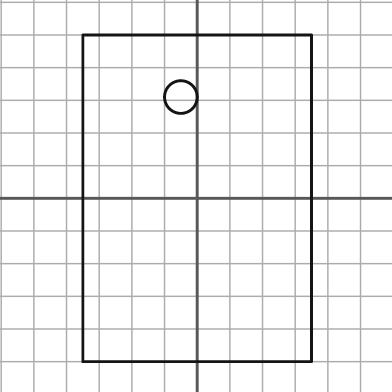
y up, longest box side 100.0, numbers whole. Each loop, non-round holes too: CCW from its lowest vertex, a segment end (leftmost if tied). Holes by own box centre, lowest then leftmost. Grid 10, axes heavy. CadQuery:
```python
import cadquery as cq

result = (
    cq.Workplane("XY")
    .moveTo(-35.0, -50.0)
    .lineTo(35.0, -50.0)
    .lineTo(35.0, 50.0)
    .lineTo(-35.0, 50.0)
    .close()
    .moveTo(-5.0, 31.0)
    .circle(5.0)
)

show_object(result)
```